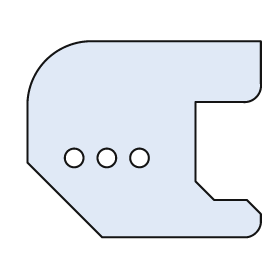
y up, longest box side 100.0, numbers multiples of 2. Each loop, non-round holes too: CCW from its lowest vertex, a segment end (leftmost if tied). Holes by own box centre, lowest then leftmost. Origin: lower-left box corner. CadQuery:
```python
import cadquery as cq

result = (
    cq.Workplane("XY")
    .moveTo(32.0, 0.0)
    .lineTo(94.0, 0.0)
    .threePointArc((98.0, 2.0), (100.0, 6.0))
    .lineTo(100.0, 10.0)
    .lineTo(94.0, 16.0)
    .lineTo(80.0, 16.0)
    .lineTo(72.0, 24.0)
    .lineTo(72.0, 58.0)
    .lineTo(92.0, 58.0)
    .threePointArc((98.0, 60.0), (100.0, 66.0))
    .lineTo(100.0, 84.0)
    .lineTo(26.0, 84.0)
    .threePointArc((8.0, 76.0), (0.0, 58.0))
    .lineTo(0.0, 32.0)
    .close()
    .moveTo(20.0, 34.0)
    .circle(4.0)
    .moveTo(34.0, 34.0)
    .circle(4.0)
    .moveTo(48.0, 34.0)
    .circle(4.0)
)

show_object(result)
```